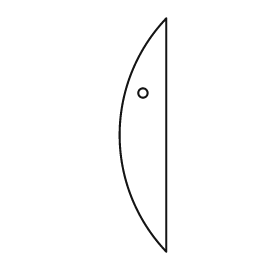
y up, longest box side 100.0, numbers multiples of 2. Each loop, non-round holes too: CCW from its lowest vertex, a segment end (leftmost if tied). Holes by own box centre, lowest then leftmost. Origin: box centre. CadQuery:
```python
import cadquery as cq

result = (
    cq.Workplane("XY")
    .moveTo(10.0, -50.0)
    .lineTo(10.0, 50.0)
    .threePointArc((-10.0, 0.0), (10.0, -50.0))
    .close()
    .moveTo(0.0, 18.0)
    .circle(2.0)
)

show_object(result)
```